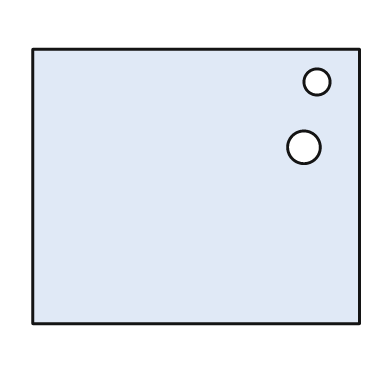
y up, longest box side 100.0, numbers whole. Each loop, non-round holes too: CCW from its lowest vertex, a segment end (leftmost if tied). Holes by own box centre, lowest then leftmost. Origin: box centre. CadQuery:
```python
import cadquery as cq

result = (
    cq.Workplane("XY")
    .moveTo(-50.0, -42.0)
    .lineTo(50.0, -42.0)
    .lineTo(50.0, 42.0)
    .lineTo(-50.0, 42.0)
    .close()
    .moveTo(33.0, 12.0)
    .circle(5.0)
    .moveTo(37.0, 32.0)
    .circle(4.0)
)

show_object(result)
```